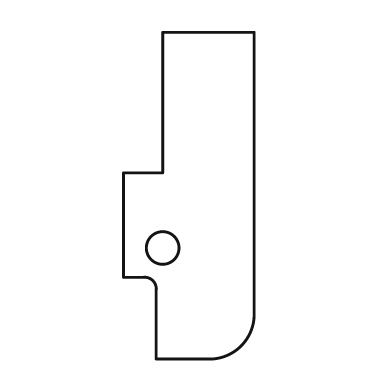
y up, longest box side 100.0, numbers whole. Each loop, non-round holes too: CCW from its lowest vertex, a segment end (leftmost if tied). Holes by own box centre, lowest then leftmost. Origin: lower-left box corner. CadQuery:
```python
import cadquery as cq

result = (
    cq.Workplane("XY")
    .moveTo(10.0, 0.0)
    .lineTo(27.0, 0.0)
    .threePointArc((36.0, 4.0), (40.0, 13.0))
    .lineTo(40.0, 100.0)
    .lineTo(12.0, 100.0)
    .lineTo(12.0, 57.0)
    .lineTo(0.0, 57.0)
    .lineTo(0.0, 25.0)
    .lineTo(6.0, 25.0)
    .threePointArc((9.0, 24.0), (10.0, 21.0))
    .close()
    .moveTo(12.0, 34.0)
    .circle(5.0)
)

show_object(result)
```